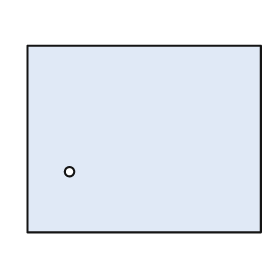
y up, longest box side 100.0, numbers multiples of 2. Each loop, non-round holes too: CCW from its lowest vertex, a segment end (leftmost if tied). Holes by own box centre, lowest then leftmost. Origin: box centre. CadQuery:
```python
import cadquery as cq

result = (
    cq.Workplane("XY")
    .moveTo(-50.0, -40.0)
    .lineTo(50.0, -40.0)
    .lineTo(50.0, 40.0)
    .lineTo(-50.0, 40.0)
    .close()
    .moveTo(-32.0, -14.0)
    .circle(2.0)
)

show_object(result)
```